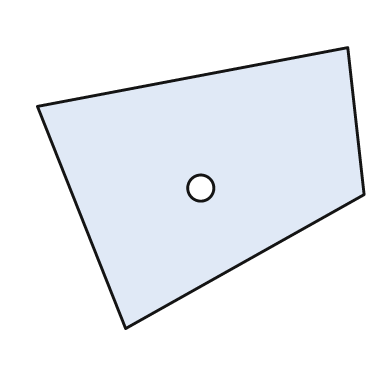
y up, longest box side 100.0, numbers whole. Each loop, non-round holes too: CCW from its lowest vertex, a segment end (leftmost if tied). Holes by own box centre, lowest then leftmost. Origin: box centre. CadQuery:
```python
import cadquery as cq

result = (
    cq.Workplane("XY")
    .moveTo(-23.0, -43.0)
    .lineTo(50.0, -2.0)
    .lineTo(45.0, 43.0)
    .lineTo(-50.0, 25.0)
    .close()
    .moveTo(0.0, 0.0)
    .circle(4.0)
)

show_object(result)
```